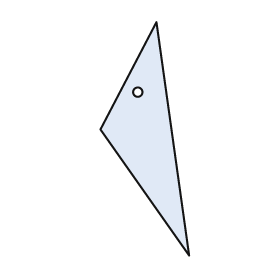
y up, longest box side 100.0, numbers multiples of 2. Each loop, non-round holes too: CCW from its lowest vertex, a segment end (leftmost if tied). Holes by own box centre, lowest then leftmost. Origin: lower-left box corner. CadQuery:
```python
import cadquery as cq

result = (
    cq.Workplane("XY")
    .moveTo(38.0, 0.0)
    .lineTo(24.0, 100.0)
    .lineTo(0.0, 54.0)
    .close()
    .moveTo(16.0, 70.0)
    .circle(2.0)
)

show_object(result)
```